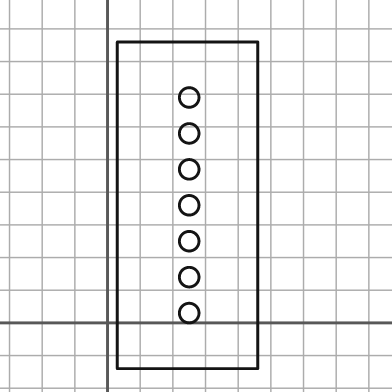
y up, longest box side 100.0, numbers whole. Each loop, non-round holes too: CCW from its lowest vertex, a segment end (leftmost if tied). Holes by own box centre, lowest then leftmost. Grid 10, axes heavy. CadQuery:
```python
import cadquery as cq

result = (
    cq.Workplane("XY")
    .moveTo(3.0, -14.0)
    .lineTo(46.0, -14.0)
    .lineTo(46.0, 86.0)
    .lineTo(3.0, 86.0)
    .close()
    .moveTo(25.0, 3.0)
    .circle(3.0)
    .moveTo(25.0, 14.0)
    .circle(3.0)
    .moveTo(25.0, 25.0)
    .circle(3.0)
    .moveTo(25.0, 36.0)
    .circle(3.0)
    .moveTo(25.0, 47.0)
    .circle(3.0)
    .moveTo(25.0, 58.0)
    .circle(3.0)
    .moveTo(25.0, 69.0)
    .circle(3.0)
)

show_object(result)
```